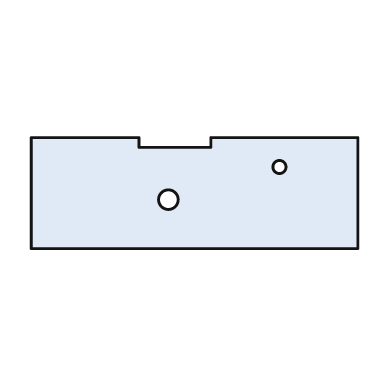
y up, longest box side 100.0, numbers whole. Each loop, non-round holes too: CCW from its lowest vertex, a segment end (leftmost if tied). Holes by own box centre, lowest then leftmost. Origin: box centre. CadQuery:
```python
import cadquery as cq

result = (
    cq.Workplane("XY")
    .moveTo(-50.0, -17.0)
    .lineTo(50.0, -17.0)
    .lineTo(50.0, 17.0)
    .lineTo(5.0, 17.0)
    .lineTo(5.0, 14.0)
    .lineTo(-17.0, 14.0)
    .lineTo(-17.0, 17.0)
    .lineTo(-50.0, 17.0)
    .close()
    .moveTo(-8.0, -2.0)
    .circle(3.0)
    .moveTo(26.0, 8.0)
    .circle(2.0)
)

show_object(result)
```